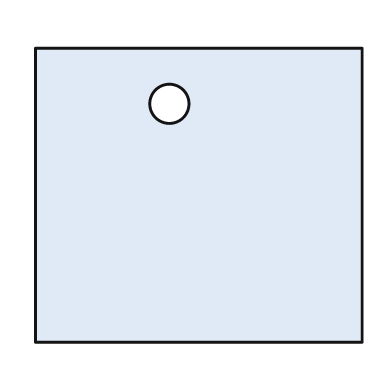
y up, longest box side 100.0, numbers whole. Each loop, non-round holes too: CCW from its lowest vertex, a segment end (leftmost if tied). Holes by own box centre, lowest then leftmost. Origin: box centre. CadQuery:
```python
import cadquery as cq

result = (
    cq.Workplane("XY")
    .moveTo(-50.0, -45.0)
    .lineTo(50.0, -45.0)
    .lineTo(50.0, 45.0)
    .lineTo(-50.0, 45.0)
    .close()
    .moveTo(-9.0, 28.0)
    .circle(6.0)
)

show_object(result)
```